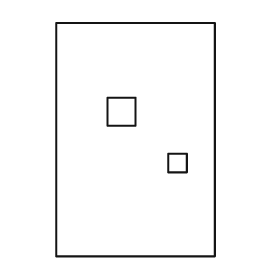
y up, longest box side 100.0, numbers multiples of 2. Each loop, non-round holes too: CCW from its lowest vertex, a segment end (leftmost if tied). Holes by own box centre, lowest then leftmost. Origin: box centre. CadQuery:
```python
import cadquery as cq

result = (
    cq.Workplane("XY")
    .moveTo(-34.0, -50.0)
    .lineTo(34.0, -50.0)
    .lineTo(34.0, 50.0)
    .lineTo(-34.0, 50.0)
    .close()
    .moveTo(14.0, -14.0)
    .lineTo(22.0, -14.0)
    .lineTo(22.0, -6.0)
    .lineTo(14.0, -6.0)
    .close()
    .moveTo(-12.0, 6.0)
    .lineTo(0.0, 6.0)
    .lineTo(0.0, 18.0)
    .lineTo(-12.0, 18.0)
    .close()
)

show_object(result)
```